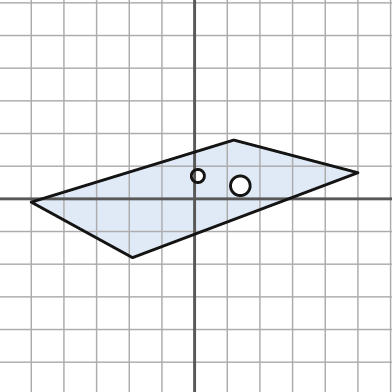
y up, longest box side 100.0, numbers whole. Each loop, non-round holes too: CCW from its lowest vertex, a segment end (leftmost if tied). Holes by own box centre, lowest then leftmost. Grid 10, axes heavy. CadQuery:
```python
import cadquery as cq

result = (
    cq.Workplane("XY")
    .moveTo(-19.0, -18.0)
    .lineTo(50.0, 8.0)
    .lineTo(12.0, 18.0)
    .lineTo(-50.0, -1.0)
    .close()
    .moveTo(14.0, 4.0)
    .circle(3.0)
    .moveTo(1.0, 7.0)
    .circle(2.0)
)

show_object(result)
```